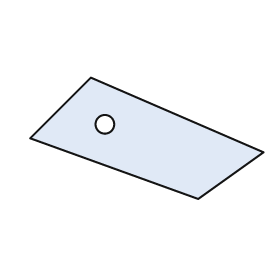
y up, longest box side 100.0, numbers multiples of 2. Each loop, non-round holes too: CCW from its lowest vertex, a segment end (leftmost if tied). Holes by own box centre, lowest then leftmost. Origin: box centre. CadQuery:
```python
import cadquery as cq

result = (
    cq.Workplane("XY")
    .moveTo(22.0, -26.0)
    .lineTo(50.0, -6.0)
    .lineTo(-24.0, 26.0)
    .lineTo(-50.0, 0.0)
    .close()
    .moveTo(-18.0, 6.0)
    .circle(4.0)
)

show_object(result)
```